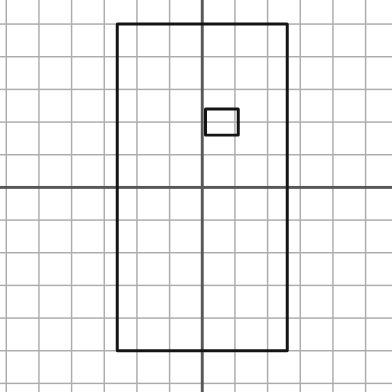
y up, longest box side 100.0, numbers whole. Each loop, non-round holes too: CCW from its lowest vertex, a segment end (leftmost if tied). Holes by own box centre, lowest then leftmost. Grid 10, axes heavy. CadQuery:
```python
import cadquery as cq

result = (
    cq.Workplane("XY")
    .moveTo(-26.0, -50.0)
    .lineTo(26.0, -50.0)
    .lineTo(26.0, 50.0)
    .lineTo(-26.0, 50.0)
    .close()
    .moveTo(1.0, 16.0)
    .lineTo(11.0, 16.0)
    .lineTo(11.0, 24.0)
    .lineTo(1.0, 24.0)
    .close()
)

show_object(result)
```